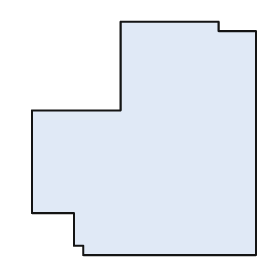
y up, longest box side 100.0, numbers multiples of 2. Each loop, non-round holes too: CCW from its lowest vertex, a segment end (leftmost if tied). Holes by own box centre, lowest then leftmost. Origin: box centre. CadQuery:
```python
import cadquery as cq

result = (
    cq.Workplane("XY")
    .moveTo(-26.0, -50.0)
    .lineTo(48.0, -50.0)
    .lineTo(48.0, 46.0)
    .lineTo(32.0, 46.0)
    .lineTo(32.0, 50.0)
    .lineTo(-10.0, 50.0)
    .lineTo(-10.0, 12.0)
    .lineTo(-48.0, 12.0)
    .lineTo(-48.0, -32.0)
    .lineTo(-30.0, -32.0)
    .lineTo(-30.0, -46.0)
    .lineTo(-26.0, -46.0)
    .close()
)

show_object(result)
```